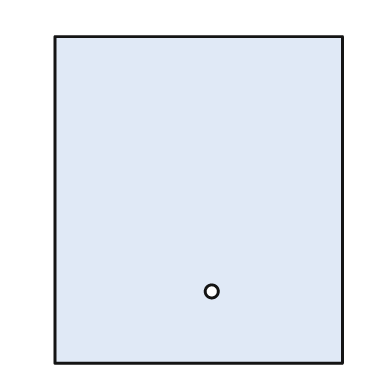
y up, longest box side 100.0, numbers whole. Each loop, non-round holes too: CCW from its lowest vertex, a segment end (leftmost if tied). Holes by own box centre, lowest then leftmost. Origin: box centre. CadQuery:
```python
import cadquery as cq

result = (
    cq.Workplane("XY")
    .moveTo(-44.0, -50.0)
    .lineTo(44.0, -50.0)
    .lineTo(44.0, 50.0)
    .lineTo(-44.0, 50.0)
    .close()
    .moveTo(4.0, -28.0)
    .circle(2.0)
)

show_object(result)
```